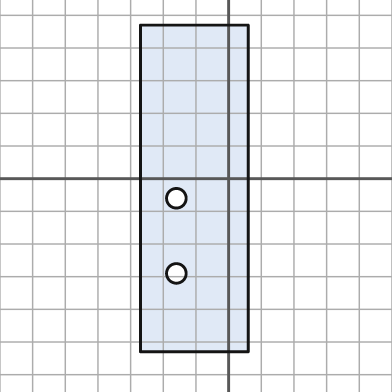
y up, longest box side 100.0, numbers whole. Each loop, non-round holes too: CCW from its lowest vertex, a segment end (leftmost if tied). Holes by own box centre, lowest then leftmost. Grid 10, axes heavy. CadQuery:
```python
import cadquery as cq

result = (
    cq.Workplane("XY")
    .moveTo(-27.0, -53.0)
    .lineTo(6.0, -53.0)
    .lineTo(6.0, 47.0)
    .lineTo(-27.0, 47.0)
    .close()
    .moveTo(-16.0, -29.0)
    .circle(3.0)
    .moveTo(-16.0, -6.0)
    .circle(3.0)
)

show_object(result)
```